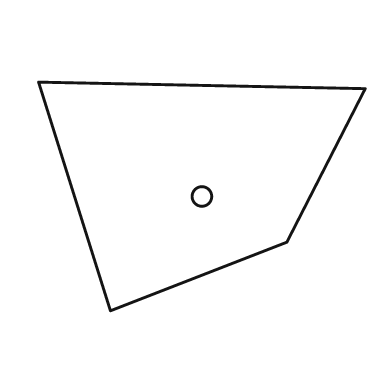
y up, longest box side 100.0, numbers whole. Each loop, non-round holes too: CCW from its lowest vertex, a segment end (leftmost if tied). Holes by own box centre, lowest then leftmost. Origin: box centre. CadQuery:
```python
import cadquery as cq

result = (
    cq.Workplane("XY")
    .moveTo(-28.0, -35.0)
    .lineTo(26.0, -14.0)
    .lineTo(50.0, 33.0)
    .lineTo(-50.0, 35.0)
    .close()
    .moveTo(0.0, 0.0)
    .circle(3.0)
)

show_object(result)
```